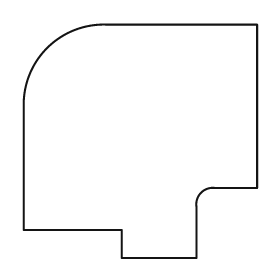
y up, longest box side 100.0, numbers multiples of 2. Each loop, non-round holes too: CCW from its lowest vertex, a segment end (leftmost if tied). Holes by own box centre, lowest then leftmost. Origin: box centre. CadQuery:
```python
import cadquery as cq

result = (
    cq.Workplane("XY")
    .moveTo(-8.0, -50.0)
    .lineTo(24.0, -50.0)
    .lineTo(24.0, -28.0)
    .threePointArc((26.0, -22.0), (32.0, -20.0))
    .lineTo(50.0, -20.0)
    .lineTo(50.0, 50.0)
    .lineTo(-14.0, 50.0)
    .threePointArc((-40.0, 40.0), (-50.0, 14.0))
    .lineTo(-50.0, -38.0)
    .lineTo(-8.0, -38.0)
    .close()
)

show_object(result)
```